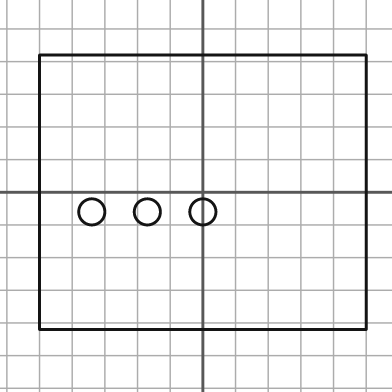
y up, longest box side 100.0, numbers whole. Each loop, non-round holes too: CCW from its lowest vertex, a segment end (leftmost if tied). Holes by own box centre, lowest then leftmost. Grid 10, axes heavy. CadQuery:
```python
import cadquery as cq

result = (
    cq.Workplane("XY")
    .moveTo(-50.0, -42.0)
    .lineTo(50.0, -42.0)
    .lineTo(50.0, 42.0)
    .lineTo(-50.0, 42.0)
    .close()
    .moveTo(-34.0, -6.0)
    .circle(4.0)
    .moveTo(-17.0, -6.0)
    .circle(4.0)
    .moveTo(0.0, -6.0)
    .circle(4.0)
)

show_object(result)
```